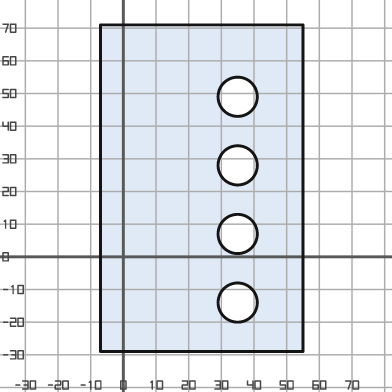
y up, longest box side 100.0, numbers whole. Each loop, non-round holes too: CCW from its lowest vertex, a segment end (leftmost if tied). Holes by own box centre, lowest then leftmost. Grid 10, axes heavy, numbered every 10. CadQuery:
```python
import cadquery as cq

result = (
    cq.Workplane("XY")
    .moveTo(-7.0, -29.0)
    .lineTo(55.0, -29.0)
    .lineTo(55.0, 71.0)
    .lineTo(-7.0, 71.0)
    .close()
    .moveTo(35.0, -14.0)
    .circle(6.0)
    .moveTo(35.0, 7.0)
    .circle(6.0)
    .moveTo(35.0, 28.0)
    .circle(6.0)
    .moveTo(35.0, 49.0)
    .circle(6.0)
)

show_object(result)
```